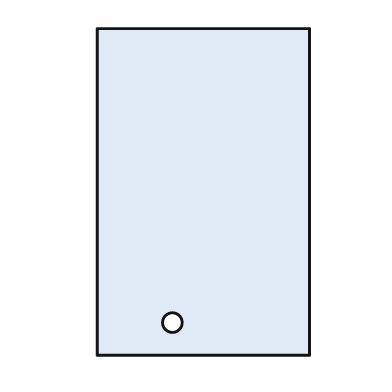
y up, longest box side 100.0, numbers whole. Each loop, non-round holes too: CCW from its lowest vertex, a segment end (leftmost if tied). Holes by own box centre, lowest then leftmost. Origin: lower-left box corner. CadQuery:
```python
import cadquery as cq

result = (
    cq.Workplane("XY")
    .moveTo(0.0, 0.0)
    .lineTo(65.0, 0.0)
    .lineTo(65.0, 100.0)
    .lineTo(0.0, 100.0)
    .close()
    .moveTo(23.0, 10.0)
    .circle(3.0)
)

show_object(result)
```